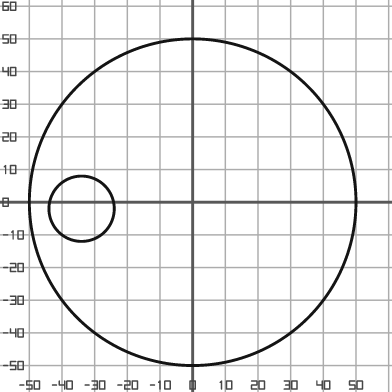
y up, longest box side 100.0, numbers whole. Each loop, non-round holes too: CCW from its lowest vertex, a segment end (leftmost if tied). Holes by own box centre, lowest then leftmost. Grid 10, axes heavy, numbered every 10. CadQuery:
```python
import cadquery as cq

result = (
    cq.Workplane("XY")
    .moveTo(0.0, 0.0)
    .circle(50.0)
    .moveTo(-34.0, -2.0)
    .circle(10.0)
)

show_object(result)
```